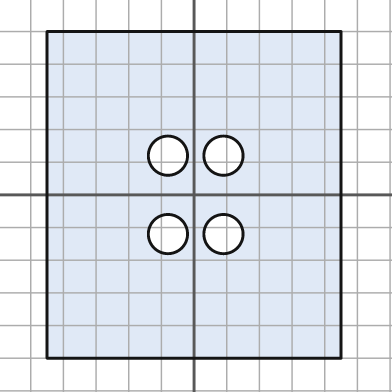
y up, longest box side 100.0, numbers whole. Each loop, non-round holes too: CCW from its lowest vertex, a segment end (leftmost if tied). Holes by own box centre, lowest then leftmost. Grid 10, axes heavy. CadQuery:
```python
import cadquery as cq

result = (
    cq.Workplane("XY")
    .moveTo(-45.0, -50.0)
    .lineTo(45.0, -50.0)
    .lineTo(45.0, 50.0)
    .lineTo(-45.0, 50.0)
    .close()
    .moveTo(-8.0, -12.0)
    .circle(6.0)
    .moveTo(9.0, -12.0)
    .circle(6.0)
    .moveTo(-8.0, 12.0)
    .circle(6.0)
    .moveTo(9.0, 12.0)
    .circle(6.0)
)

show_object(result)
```